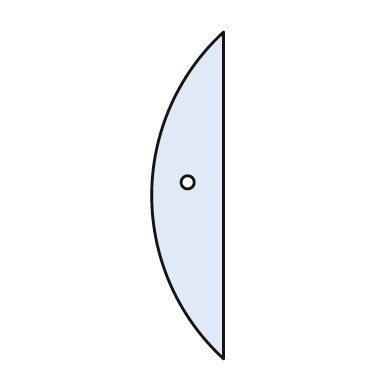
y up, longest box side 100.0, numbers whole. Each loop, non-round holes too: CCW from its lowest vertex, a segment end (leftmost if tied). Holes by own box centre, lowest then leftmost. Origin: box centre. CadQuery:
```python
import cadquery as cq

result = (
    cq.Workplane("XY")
    .moveTo(11.0, -50.0)
    .lineTo(11.0, 50.0)
    .threePointArc((-11.0, 0.0), (11.0, -50.0))
    .close()
    .moveTo(0.0, 4.0)
    .circle(2.0)
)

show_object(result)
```